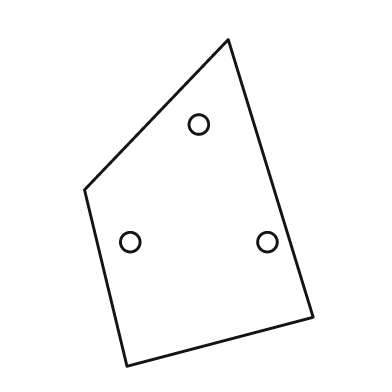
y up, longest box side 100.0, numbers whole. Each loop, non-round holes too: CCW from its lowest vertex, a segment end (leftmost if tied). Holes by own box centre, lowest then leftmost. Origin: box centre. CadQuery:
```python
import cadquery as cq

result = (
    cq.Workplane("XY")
    .moveTo(-22.0, -50.0)
    .lineTo(35.0, -35.0)
    .lineTo(9.0, 50.0)
    .lineTo(-35.0, 4.0)
    .close()
    .moveTo(-21.0, -12.0)
    .circle(3.0)
    .moveTo(21.0, -12.0)
    .circle(3.0)
    .moveTo(0.0, 24.0)
    .circle(3.0)
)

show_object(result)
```